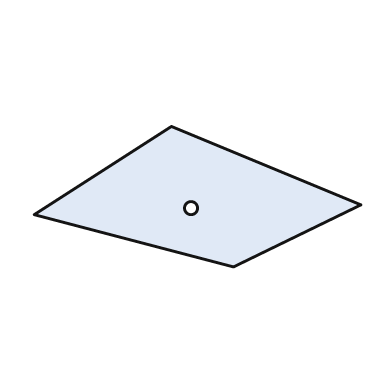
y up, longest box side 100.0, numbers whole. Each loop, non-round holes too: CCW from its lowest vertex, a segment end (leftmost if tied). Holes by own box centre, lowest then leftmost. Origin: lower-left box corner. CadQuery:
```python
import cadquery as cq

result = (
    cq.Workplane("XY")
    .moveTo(61.0, 0.0)
    .lineTo(100.0, 19.0)
    .lineTo(42.0, 43.0)
    .lineTo(0.0, 16.0)
    .close()
    .moveTo(48.0, 18.0)
    .circle(2.0)
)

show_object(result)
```